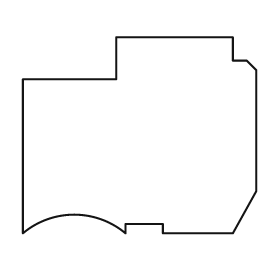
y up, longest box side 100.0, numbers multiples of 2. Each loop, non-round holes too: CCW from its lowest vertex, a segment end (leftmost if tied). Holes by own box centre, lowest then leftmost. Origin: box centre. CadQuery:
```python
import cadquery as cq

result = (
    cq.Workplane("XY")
    .moveTo(-50.0, -42.0)
    .threePointArc((-28.0, -34.0), (-6.0, -42.0))
    .lineTo(-6.0, -38.0)
    .lineTo(10.0, -38.0)
    .lineTo(10.0, -42.0)
    .lineTo(40.0, -42.0)
    .lineTo(50.0, -24.0)
    .lineTo(50.0, 28.0)
    .lineTo(46.0, 32.0)
    .lineTo(40.0, 32.0)
    .lineTo(40.0, 42.0)
    .lineTo(-10.0, 42.0)
    .lineTo(-10.0, 24.0)
    .lineTo(-50.0, 24.0)
    .close()
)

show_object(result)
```